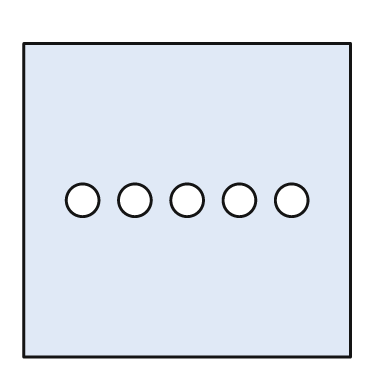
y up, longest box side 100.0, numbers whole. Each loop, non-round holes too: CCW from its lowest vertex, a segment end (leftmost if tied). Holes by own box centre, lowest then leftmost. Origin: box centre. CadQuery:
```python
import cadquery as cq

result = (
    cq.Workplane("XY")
    .moveTo(-50.0, -48.0)
    .lineTo(50.0, -48.0)
    .lineTo(50.0, 48.0)
    .lineTo(-50.0, 48.0)
    .close()
    .moveTo(-32.0, 0.0)
    .circle(5.0)
    .moveTo(-16.0, 0.0)
    .circle(5.0)
    .moveTo(0.0, 0.0)
    .circle(5.0)
    .moveTo(16.0, 0.0)
    .circle(5.0)
    .moveTo(32.0, 0.0)
    .circle(5.0)
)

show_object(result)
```